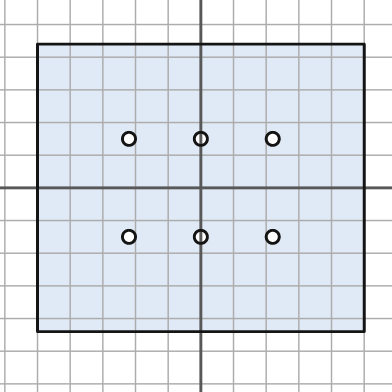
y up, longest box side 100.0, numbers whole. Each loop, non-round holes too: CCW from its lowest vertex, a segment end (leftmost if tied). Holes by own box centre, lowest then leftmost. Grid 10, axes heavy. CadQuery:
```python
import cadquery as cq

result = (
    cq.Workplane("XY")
    .moveTo(-50.0, -44.0)
    .lineTo(50.0, -44.0)
    .lineTo(50.0, 44.0)
    .lineTo(-50.0, 44.0)
    .close()
    .moveTo(-22.0, -15.0)
    .circle(2.0)
    .moveTo(0.0, -15.0)
    .circle(2.0)
    .moveTo(22.0, -15.0)
    .circle(2.0)
    .moveTo(-22.0, 15.0)
    .circle(2.0)
    .moveTo(0.0, 15.0)
    .circle(2.0)
    .moveTo(22.0, 15.0)
    .circle(2.0)
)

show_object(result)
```